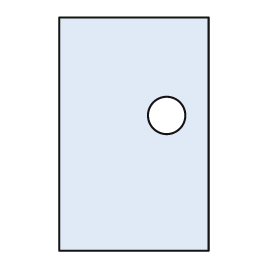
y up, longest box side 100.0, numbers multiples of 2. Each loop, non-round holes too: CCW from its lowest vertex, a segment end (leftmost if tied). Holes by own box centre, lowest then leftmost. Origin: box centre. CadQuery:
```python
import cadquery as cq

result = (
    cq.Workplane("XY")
    .moveTo(-32.0, -50.0)
    .lineTo(32.0, -50.0)
    .lineTo(32.0, 50.0)
    .lineTo(-32.0, 50.0)
    .close()
    .moveTo(14.0, 8.0)
    .circle(8.0)
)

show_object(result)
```